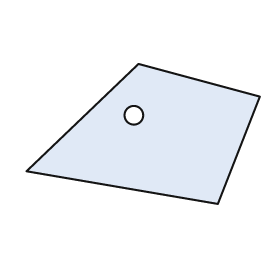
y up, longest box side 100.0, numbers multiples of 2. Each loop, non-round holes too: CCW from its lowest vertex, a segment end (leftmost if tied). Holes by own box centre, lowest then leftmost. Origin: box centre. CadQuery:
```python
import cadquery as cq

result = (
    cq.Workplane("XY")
    .moveTo(32.0, -30.0)
    .lineTo(50.0, 16.0)
    .lineTo(-2.0, 30.0)
    .lineTo(-50.0, -16.0)
    .close()
    .moveTo(-4.0, 8.0)
    .circle(4.0)
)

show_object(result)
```